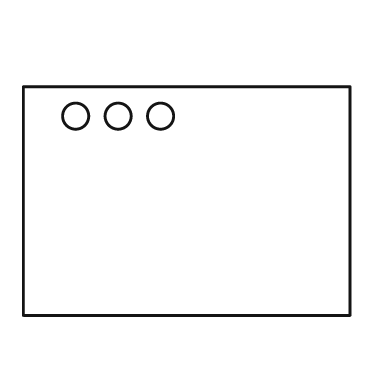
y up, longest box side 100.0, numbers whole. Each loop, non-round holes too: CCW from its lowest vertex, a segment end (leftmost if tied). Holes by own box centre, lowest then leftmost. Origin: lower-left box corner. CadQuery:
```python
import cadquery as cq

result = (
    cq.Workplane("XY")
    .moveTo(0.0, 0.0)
    .lineTo(100.0, 0.0)
    .lineTo(100.0, 70.0)
    .lineTo(0.0, 70.0)
    .close()
    .moveTo(16.0, 61.0)
    .circle(4.0)
    .moveTo(29.0, 61.0)
    .circle(4.0)
    .moveTo(42.0, 61.0)
    .circle(4.0)
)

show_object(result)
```